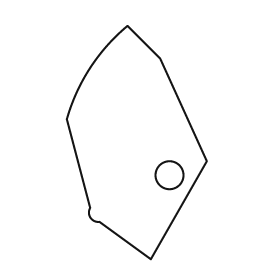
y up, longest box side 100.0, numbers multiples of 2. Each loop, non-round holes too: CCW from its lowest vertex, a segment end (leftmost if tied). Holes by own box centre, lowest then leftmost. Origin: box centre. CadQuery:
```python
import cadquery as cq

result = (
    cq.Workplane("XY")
    .moveTo(6.0, -50.0)
    .lineTo(30.0, -8.0)
    .lineTo(10.0, 36.0)
    .lineTo(-4.0, 50.0)
    .threePointArc((-20.0, 32.0), (-30.0, 10.0))
    .lineTo(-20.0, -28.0)
    .threePointArc((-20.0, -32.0), (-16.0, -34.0))
    .close()
    .moveTo(14.0, -14.0)
    .circle(6.0)
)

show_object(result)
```